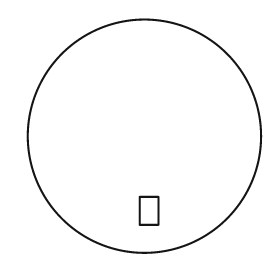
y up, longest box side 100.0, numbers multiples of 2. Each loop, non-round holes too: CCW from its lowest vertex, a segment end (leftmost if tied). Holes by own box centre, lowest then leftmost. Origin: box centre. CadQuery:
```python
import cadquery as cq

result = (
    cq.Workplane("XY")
    .moveTo(0.0, 0.0)
    .circle(50.0)
    .moveTo(-2.0, -38.0)
    .lineTo(6.0, -38.0)
    .lineTo(6.0, -26.0)
    .lineTo(-2.0, -26.0)
    .close()
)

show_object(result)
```